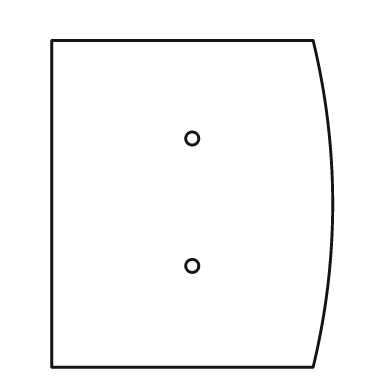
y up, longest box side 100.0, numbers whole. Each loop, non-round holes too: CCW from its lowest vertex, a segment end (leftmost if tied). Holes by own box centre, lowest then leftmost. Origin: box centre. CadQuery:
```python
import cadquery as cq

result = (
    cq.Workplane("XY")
    .moveTo(-43.0, -50.0)
    .lineTo(37.0, -50.0)
    .threePointArc((43.0, 0.0), (37.0, 50.0))
    .lineTo(-43.0, 50.0)
    .close()
    .moveTo(0.0, -19.0)
    .circle(2.0)
    .moveTo(0.0, 20.0)
    .circle(2.0)
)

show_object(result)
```